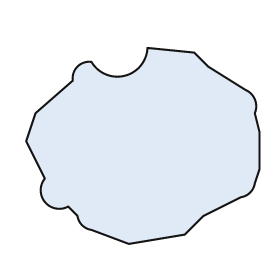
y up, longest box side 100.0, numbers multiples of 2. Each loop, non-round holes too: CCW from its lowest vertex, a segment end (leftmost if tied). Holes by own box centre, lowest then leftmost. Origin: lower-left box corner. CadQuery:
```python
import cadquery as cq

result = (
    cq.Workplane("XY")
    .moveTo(44.0, 0.0)
    .lineTo(68.0, 4.0)
    .lineTo(76.0, 12.0)
    .lineTo(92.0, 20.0)
    .threePointArc((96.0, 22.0), (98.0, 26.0))
    .lineTo(100.0, 32.0)
    .lineTo(100.0, 48.0)
    .lineTo(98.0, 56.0)
    .threePointArc((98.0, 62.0), (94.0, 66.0))
    .lineTo(78.0, 76.0)
    .lineTo(72.0, 82.0)
    .lineTo(52.0, 84.0)
    .threePointArc((42.0, 72.0), (28.0, 78.0))
    .threePointArc((22.0, 76.0), (20.0, 70.0))
    .lineTo(4.0, 56.0)
    .lineTo(0.0, 44.0)
    .lineTo(8.0, 28.0)
    .threePointArc((8.0, 18.0), (18.0, 16.0))
    .lineTo(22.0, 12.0)
    .threePointArc((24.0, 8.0), (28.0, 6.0))
    .close()
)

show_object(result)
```